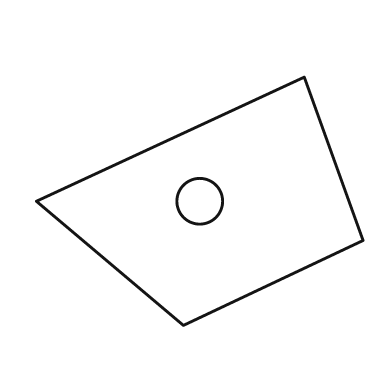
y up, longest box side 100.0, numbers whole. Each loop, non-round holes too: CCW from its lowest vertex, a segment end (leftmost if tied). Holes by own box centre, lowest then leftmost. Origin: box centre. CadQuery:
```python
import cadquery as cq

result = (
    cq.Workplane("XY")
    .moveTo(-5.0, -38.0)
    .lineTo(50.0, -12.0)
    .lineTo(32.0, 38.0)
    .lineTo(-50.0, 0.0)
    .close()
    .moveTo(0.0, 0.0)
    .circle(7.0)
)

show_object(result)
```